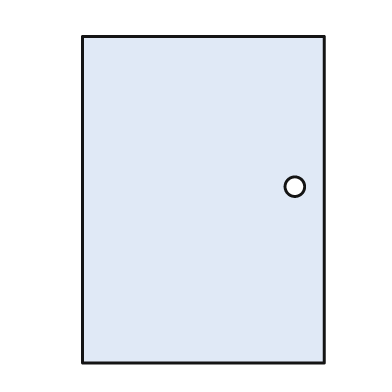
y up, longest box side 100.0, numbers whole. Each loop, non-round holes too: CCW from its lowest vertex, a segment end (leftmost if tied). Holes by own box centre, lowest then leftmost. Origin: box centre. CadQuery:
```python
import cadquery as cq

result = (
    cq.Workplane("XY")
    .moveTo(-37.0, -50.0)
    .lineTo(37.0, -50.0)
    .lineTo(37.0, 50.0)
    .lineTo(-37.0, 50.0)
    .close()
    .moveTo(28.0, 4.0)
    .circle(3.0)
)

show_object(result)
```